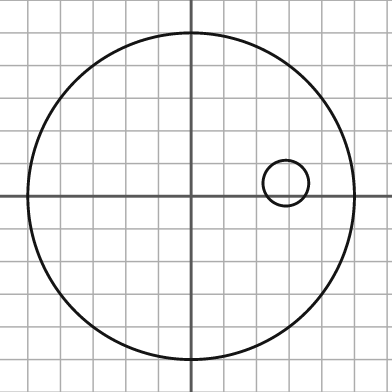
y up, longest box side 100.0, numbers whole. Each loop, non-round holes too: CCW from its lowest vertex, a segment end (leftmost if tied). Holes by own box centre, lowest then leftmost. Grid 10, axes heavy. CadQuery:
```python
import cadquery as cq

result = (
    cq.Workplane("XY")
    .moveTo(0.0, 0.0)
    .circle(50.0)
    .moveTo(29.0, 4.0)
    .circle(7.0)
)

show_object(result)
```